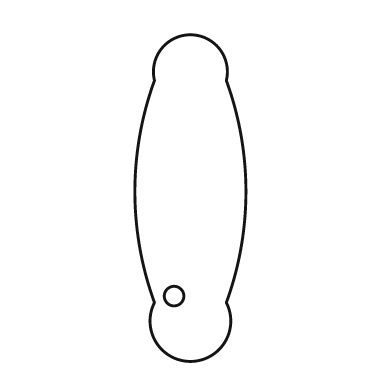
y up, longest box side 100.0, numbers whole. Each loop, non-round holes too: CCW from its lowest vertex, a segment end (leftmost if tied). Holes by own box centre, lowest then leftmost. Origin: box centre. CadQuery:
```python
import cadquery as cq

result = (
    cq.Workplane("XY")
    .moveTo(-11.0, -32.0)
    .threePointArc((0.0, -50.0), (11.0, -32.0))
    .threePointArc((17.0, 2.0), (11.0, 36.0))
    .threePointArc((0.0, 50.0), (-11.0, 36.0))
    .threePointArc((-17.0, 2.0), (-11.0, -32.0))
    .close()
    .moveTo(-5.0, -30.0)
    .circle(3.0)
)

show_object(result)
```